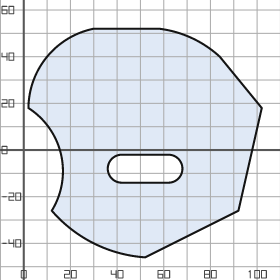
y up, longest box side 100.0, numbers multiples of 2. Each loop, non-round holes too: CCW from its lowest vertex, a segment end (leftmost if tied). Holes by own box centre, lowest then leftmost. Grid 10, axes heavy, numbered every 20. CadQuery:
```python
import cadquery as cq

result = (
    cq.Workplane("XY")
    .moveTo(52.0, -46.0)
    .lineTo(92.0, -26.0)
    .lineTo(102.0, 18.0)
    .lineTo(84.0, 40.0)
    .threePointArc((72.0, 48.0), (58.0, 52.0))
    .lineTo(30.0, 52.0)
    .threePointArc((10.0, 40.0), (2.0, 18.0))
    .threePointArc((16.0, -2.0), (12.0, -26.0))
    .threePointArc((30.0, -40.0), (52.0, -46.0))
    .close()
    .moveTo(42.0, -14.0)
    .lineTo(62.0, -14.0)
    .threePointArc((68.0, -8.0), (62.0, -2.0))
    .lineTo(42.0, -2.0)
    .threePointArc((36.0, -8.0), (42.0, -14.0))
    .close()
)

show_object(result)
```